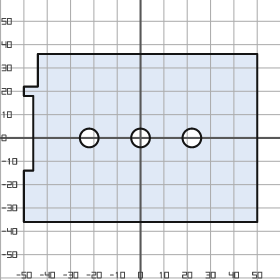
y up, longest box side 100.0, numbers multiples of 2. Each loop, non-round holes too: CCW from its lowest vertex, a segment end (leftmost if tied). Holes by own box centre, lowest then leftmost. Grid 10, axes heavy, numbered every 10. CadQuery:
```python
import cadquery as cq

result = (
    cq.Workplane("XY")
    .moveTo(-50.0, -36.0)
    .lineTo(50.0, -36.0)
    .lineTo(50.0, 36.0)
    .lineTo(-44.0, 36.0)
    .lineTo(-44.0, 22.0)
    .lineTo(-50.0, 22.0)
    .lineTo(-50.0, 18.0)
    .lineTo(-46.0, 18.0)
    .lineTo(-46.0, -14.0)
    .lineTo(-50.0, -14.0)
    .close()
    .moveTo(-22.0, 0.0)
    .circle(4.0)
    .moveTo(0.0, 0.0)
    .circle(4.0)
    .moveTo(22.0, 0.0)
    .circle(4.0)
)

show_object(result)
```